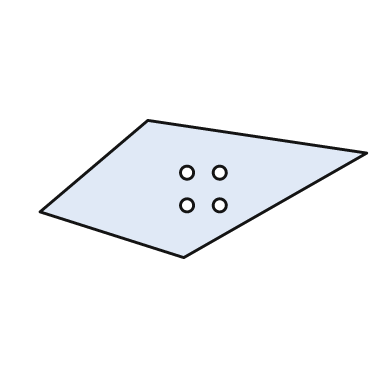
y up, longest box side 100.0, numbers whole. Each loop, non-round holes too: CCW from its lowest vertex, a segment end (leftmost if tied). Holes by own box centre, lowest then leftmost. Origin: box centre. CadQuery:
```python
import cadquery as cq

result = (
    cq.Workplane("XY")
    .moveTo(-6.0, -21.0)
    .lineTo(50.0, 11.0)
    .lineTo(-17.0, 21.0)
    .lineTo(-50.0, -7.0)
    .close()
    .moveTo(-5.0, -5.0)
    .circle(2.0)
    .moveTo(5.0, -5.0)
    .circle(2.0)
    .moveTo(-5.0, 5.0)
    .circle(2.0)
    .moveTo(5.0, 5.0)
    .circle(2.0)
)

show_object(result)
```